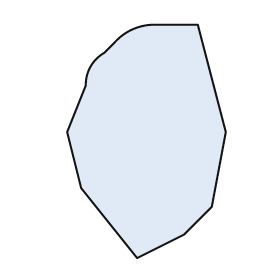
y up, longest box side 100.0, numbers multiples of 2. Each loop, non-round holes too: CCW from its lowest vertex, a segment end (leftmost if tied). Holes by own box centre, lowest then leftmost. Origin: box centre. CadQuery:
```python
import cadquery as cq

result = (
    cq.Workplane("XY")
    .moveTo(-4.0, -50.0)
    .lineTo(16.0, -40.0)
    .lineTo(28.0, -28.0)
    .lineTo(34.0, 4.0)
    .lineTo(22.0, 50.0)
    .lineTo(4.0, 50.0)
    .threePointArc((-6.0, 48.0), (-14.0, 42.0))
    .lineTo(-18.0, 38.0)
    .threePointArc((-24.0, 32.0), (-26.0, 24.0))
    .lineTo(-34.0, 4.0)
    .lineTo(-28.0, -20.0)
    .close()
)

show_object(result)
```